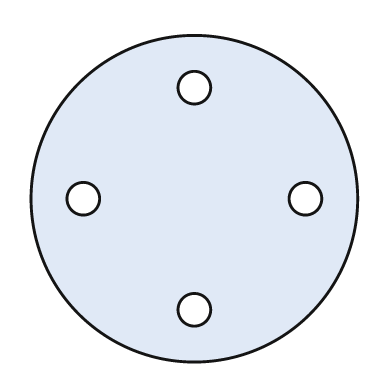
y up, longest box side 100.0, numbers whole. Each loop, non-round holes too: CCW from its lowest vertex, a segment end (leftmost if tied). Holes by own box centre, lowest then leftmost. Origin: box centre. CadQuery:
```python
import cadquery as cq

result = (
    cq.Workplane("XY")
    .moveTo(0.0, 0.0)
    .circle(50.0)
    .moveTo(0.0, -34.0)
    .circle(5.0)
    .moveTo(-34.0, 0.0)
    .circle(5.0)
    .moveTo(34.0, 0.0)
    .circle(5.0)
    .moveTo(0.0, 34.0)
    .circle(5.0)
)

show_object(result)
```